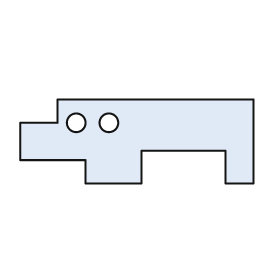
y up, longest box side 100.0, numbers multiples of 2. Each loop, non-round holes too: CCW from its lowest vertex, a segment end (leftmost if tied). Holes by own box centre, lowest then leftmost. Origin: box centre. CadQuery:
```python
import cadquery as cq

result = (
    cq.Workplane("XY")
    .moveTo(-22.0, -18.0)
    .lineTo(2.0, -18.0)
    .lineTo(2.0, -4.0)
    .lineTo(38.0, -4.0)
    .lineTo(38.0, -18.0)
    .lineTo(50.0, -18.0)
    .lineTo(50.0, 18.0)
    .lineTo(-34.0, 18.0)
    .lineTo(-34.0, 8.0)
    .lineTo(-50.0, 8.0)
    .lineTo(-50.0, -8.0)
    .lineTo(-22.0, -8.0)
    .close()
    .moveTo(-26.0, 8.0)
    .circle(4.0)
    .moveTo(-12.0, 8.0)
    .circle(4.0)
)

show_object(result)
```